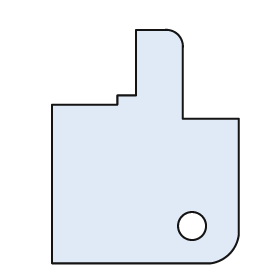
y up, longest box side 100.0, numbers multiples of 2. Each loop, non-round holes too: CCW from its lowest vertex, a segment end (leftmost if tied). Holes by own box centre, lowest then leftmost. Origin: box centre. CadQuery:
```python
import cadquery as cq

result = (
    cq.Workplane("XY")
    .moveTo(-40.0, -50.0)
    .lineTo(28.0, -50.0)
    .threePointArc((36.0, -46.0), (40.0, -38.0))
    .lineTo(40.0, 12.0)
    .lineTo(16.0, 12.0)
    .lineTo(16.0, 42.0)
    .threePointArc((14.0, 48.0), (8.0, 50.0))
    .lineTo(-4.0, 50.0)
    .lineTo(-4.0, 22.0)
    .lineTo(-12.0, 22.0)
    .lineTo(-12.0, 18.0)
    .lineTo(-40.0, 18.0)
    .close()
    .moveTo(20.0, -34.0)
    .circle(6.0)
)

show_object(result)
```